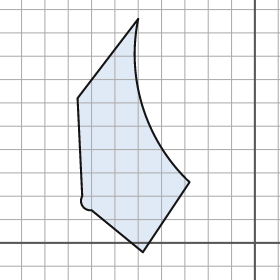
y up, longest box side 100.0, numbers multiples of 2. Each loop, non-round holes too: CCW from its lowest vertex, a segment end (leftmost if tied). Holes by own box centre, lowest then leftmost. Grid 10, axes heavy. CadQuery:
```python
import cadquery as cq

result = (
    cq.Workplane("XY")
    .moveTo(-48.0, -4.0)
    .lineTo(-28.0, 26.0)
    .threePointArc((-48.0, 58.0), (-50.0, 96.0))
    .lineTo(-76.0, 62.0)
    .lineTo(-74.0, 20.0)
    .threePointArc((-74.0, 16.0), (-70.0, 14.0))
    .close()
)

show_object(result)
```